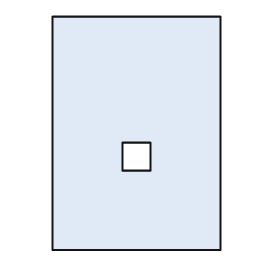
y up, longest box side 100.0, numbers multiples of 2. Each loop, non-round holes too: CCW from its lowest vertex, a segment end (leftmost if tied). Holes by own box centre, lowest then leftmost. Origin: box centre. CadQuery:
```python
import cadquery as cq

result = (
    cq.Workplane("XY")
    .moveTo(-36.0, -50.0)
    .lineTo(36.0, -50.0)
    .lineTo(36.0, 50.0)
    .lineTo(-36.0, 50.0)
    .close()
    .moveTo(-6.0, -16.0)
    .lineTo(6.0, -16.0)
    .lineTo(6.0, -4.0)
    .lineTo(-6.0, -4.0)
    .close()
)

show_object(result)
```